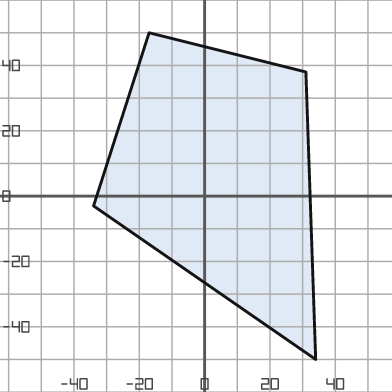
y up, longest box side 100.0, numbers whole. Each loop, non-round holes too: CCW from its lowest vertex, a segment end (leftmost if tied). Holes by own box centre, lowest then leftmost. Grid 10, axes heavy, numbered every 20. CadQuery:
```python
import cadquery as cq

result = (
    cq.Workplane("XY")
    .moveTo(34.0, -50.0)
    .lineTo(31.0, 38.0)
    .lineTo(-17.0, 50.0)
    .lineTo(-34.0, -3.0)
    .close()
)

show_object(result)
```